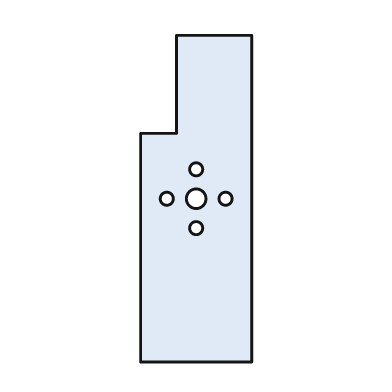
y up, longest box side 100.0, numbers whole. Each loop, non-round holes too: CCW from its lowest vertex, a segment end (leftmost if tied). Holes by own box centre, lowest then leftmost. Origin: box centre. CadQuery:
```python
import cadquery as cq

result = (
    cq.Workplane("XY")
    .moveTo(-17.0, -50.0)
    .lineTo(17.0, -50.0)
    .lineTo(17.0, 50.0)
    .lineTo(-6.0, 50.0)
    .lineTo(-6.0, 20.0)
    .lineTo(-17.0, 20.0)
    .close()
    .moveTo(0.0, -9.0)
    .circle(2.0)
    .moveTo(-9.0, 0.0)
    .circle(2.0)
    .moveTo(0.0, 0.0)
    .circle(3.0)
    .moveTo(9.0, 0.0)
    .circle(2.0)
    .moveTo(0.0, 9.0)
    .circle(2.0)
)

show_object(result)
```